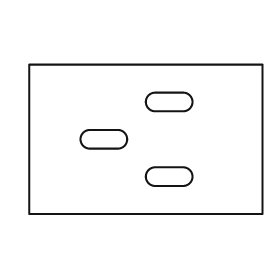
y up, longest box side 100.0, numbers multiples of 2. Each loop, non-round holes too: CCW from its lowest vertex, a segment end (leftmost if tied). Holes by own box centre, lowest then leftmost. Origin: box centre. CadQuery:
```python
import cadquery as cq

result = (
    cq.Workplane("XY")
    .moveTo(-50.0, -32.0)
    .lineTo(50.0, -32.0)
    .lineTo(50.0, 32.0)
    .lineTo(-50.0, 32.0)
    .close()
    .moveTo(4.0, -20.0)
    .lineTo(16.0, -20.0)
    .threePointArc((20.0, -16.0), (16.0, -12.0))
    .lineTo(4.0, -12.0)
    .threePointArc((0.0, -16.0), (4.0, -20.0))
    .close()
    .moveTo(-24.0, -4.0)
    .lineTo(-12.0, -4.0)
    .threePointArc((-8.0, 0.0), (-12.0, 4.0))
    .lineTo(-24.0, 4.0)
    .threePointArc((-28.0, 0.0), (-24.0, -4.0))
    .close()
    .moveTo(4.0, 12.0)
    .lineTo(16.0, 12.0)
    .threePointArc((20.0, 16.0), (16.0, 20.0))
    .lineTo(4.0, 20.0)
    .threePointArc((0.0, 16.0), (4.0, 12.0))
    .close()
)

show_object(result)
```